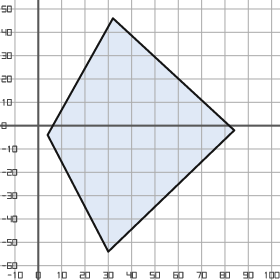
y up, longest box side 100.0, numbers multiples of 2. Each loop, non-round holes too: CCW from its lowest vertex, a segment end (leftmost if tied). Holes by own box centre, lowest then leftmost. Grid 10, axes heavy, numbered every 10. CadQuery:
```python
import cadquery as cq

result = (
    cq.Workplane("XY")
    .moveTo(30.0, -54.0)
    .lineTo(84.0, -2.0)
    .lineTo(32.0, 46.0)
    .lineTo(4.0, -4.0)
    .close()
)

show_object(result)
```